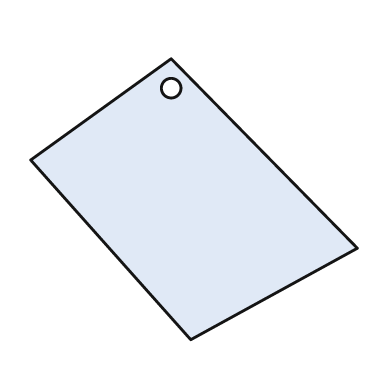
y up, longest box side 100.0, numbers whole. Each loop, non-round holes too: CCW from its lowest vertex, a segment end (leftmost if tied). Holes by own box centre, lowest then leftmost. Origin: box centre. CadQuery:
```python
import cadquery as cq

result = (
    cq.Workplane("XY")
    .moveTo(-1.0, -43.0)
    .lineTo(50.0, -15.0)
    .lineTo(-7.0, 43.0)
    .lineTo(-50.0, 12.0)
    .close()
    .moveTo(-7.0, 34.0)
    .circle(3.0)
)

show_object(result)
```